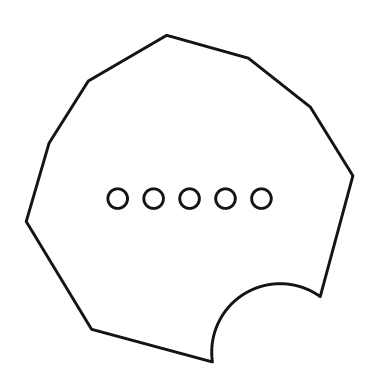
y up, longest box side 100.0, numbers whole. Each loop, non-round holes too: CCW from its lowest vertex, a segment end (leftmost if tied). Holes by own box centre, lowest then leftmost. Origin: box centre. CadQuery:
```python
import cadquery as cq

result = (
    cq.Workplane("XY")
    .moveTo(7.0, -50.0)
    .threePointArc((17.0, -29.0), (40.0, -30.0))
    .lineTo(50.0, 7.0)
    .lineTo(37.0, 28.0)
    .lineTo(18.0, 43.0)
    .lineTo(-7.0, 50.0)
    .lineTo(-31.0, 36.0)
    .lineTo(-43.0, 17.0)
    .lineTo(-50.0, -7.0)
    .lineTo(-30.0, -40.0)
    .close()
    .moveTo(-22.0, 0.0)
    .circle(3.0)
    .moveTo(-11.0, 0.0)
    .circle(3.0)
    .moveTo(0.0, 0.0)
    .circle(3.0)
    .moveTo(11.0, 0.0)
    .circle(3.0)
    .moveTo(22.0, 0.0)
    .circle(3.0)
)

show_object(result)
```